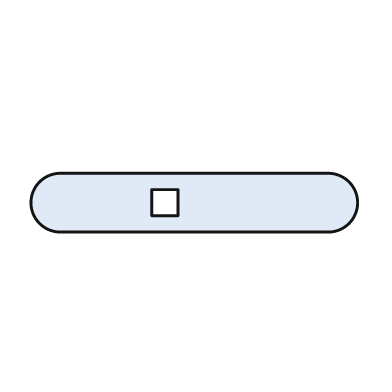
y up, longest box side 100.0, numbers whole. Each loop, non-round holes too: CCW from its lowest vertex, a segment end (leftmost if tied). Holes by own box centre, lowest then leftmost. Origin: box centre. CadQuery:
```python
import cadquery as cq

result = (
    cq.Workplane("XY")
    .moveTo(-41.0, -9.0)
    .lineTo(41.0, -9.0)
    .threePointArc((50.0, 0.0), (41.0, 9.0))
    .lineTo(-41.0, 9.0)
    .threePointArc((-50.0, 0.0), (-41.0, -9.0))
    .close()
    .moveTo(-13.0, -4.0)
    .lineTo(-5.0, -4.0)
    .lineTo(-5.0, 4.0)
    .lineTo(-13.0, 4.0)
    .close()
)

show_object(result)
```